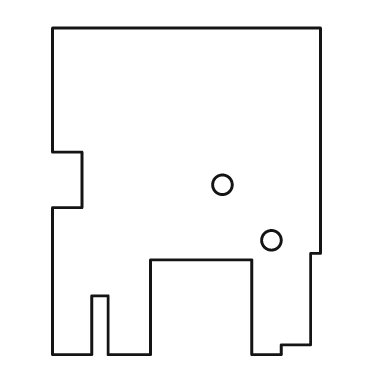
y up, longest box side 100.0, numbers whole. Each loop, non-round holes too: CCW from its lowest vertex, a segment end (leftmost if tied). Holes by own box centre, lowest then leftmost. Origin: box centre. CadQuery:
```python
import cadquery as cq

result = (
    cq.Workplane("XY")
    .moveTo(-41.0, -50.0)
    .lineTo(-29.0, -50.0)
    .lineTo(-29.0, -32.0)
    .lineTo(-24.0, -32.0)
    .lineTo(-24.0, -50.0)
    .lineTo(-11.0, -50.0)
    .lineTo(-11.0, -21.0)
    .lineTo(20.0, -21.0)
    .lineTo(20.0, -50.0)
    .lineTo(29.0, -50.0)
    .lineTo(29.0, -47.0)
    .lineTo(38.0, -47.0)
    .lineTo(38.0, -19.0)
    .lineTo(41.0, -19.0)
    .lineTo(41.0, 50.0)
    .lineTo(-41.0, 50.0)
    .lineTo(-41.0, 12.0)
    .lineTo(-32.0, 12.0)
    .lineTo(-32.0, -5.0)
    .lineTo(-41.0, -5.0)
    .close()
    .moveTo(26.0, -15.0)
    .circle(3.0)
    .moveTo(11.0, 2.0)
    .circle(3.0)
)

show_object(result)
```